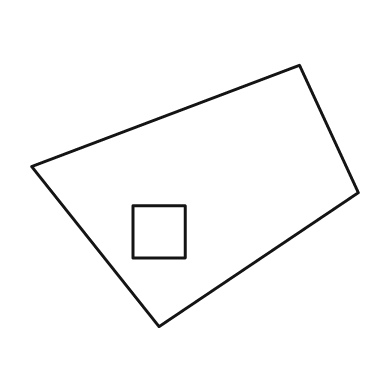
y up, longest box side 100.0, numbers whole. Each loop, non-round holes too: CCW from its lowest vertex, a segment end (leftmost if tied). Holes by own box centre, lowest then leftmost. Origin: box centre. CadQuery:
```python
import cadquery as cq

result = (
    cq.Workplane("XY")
    .moveTo(-11.0, -40.0)
    .lineTo(50.0, 1.0)
    .lineTo(32.0, 40.0)
    .lineTo(-50.0, 9.0)
    .close()
    .moveTo(-19.0, -19.0)
    .lineTo(-3.0, -19.0)
    .lineTo(-3.0, -3.0)
    .lineTo(-19.0, -3.0)
    .close()
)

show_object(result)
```